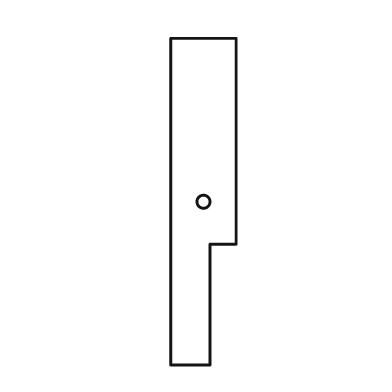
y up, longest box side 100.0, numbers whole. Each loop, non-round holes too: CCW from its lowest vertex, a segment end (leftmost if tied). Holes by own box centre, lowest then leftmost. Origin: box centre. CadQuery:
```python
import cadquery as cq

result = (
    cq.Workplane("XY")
    .moveTo(-10.0, -50.0)
    .lineTo(2.0, -50.0)
    .lineTo(2.0, -13.0)
    .lineTo(10.0, -13.0)
    .lineTo(10.0, 50.0)
    .lineTo(-10.0, 50.0)
    .close()
    .moveTo(0.0, 0.0)
    .circle(2.0)
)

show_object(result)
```